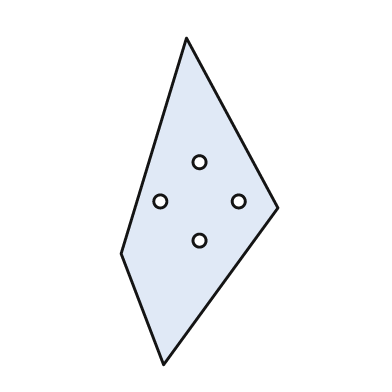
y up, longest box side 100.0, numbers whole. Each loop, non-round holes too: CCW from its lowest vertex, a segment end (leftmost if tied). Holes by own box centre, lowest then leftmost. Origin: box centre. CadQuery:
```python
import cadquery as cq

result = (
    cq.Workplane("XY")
    .moveTo(-11.0, -50.0)
    .lineTo(24.0, -2.0)
    .lineTo(-4.0, 50.0)
    .lineTo(-24.0, -16.0)
    .close()
    .moveTo(0.0, -12.0)
    .circle(2.0)
    .moveTo(-12.0, 0.0)
    .circle(2.0)
    .moveTo(12.0, 0.0)
    .circle(2.0)
    .moveTo(0.0, 12.0)
    .circle(2.0)
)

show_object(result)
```